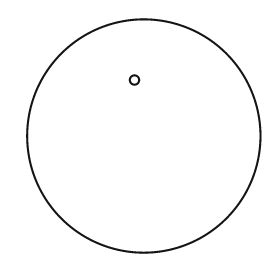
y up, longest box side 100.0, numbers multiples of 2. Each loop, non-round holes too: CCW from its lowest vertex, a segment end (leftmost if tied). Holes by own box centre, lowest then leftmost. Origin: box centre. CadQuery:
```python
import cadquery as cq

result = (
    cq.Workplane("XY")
    .moveTo(0.0, 0.0)
    .circle(50.0)
    .moveTo(-4.0, 24.0)
    .circle(2.0)
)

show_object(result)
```